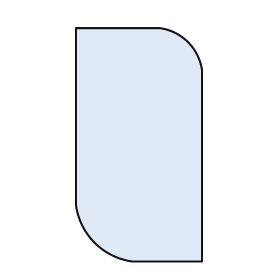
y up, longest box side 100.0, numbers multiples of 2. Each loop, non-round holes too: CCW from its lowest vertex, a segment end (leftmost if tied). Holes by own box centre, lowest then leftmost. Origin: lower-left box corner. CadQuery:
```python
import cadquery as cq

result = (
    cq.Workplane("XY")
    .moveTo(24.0, 0.0)
    .lineTo(54.0, 0.0)
    .lineTo(54.0, 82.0)
    .threePointArc((48.0, 94.0), (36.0, 100.0))
    .lineTo(0.0, 100.0)
    .lineTo(0.0, 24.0)
    .threePointArc((8.0, 8.0), (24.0, 0.0))
    .close()
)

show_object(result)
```